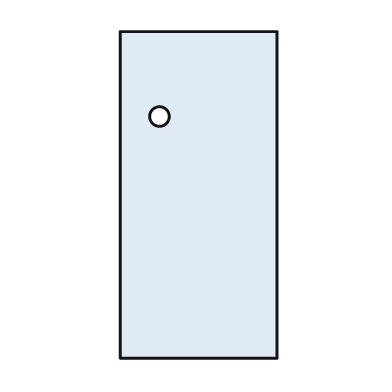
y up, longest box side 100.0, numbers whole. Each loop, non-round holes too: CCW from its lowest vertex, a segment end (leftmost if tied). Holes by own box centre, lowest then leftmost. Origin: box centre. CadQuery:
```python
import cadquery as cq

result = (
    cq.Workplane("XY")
    .moveTo(-24.0, -50.0)
    .lineTo(24.0, -50.0)
    .lineTo(24.0, 50.0)
    .lineTo(-24.0, 50.0)
    .close()
    .moveTo(-12.0, 24.0)
    .circle(3.0)
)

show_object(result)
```